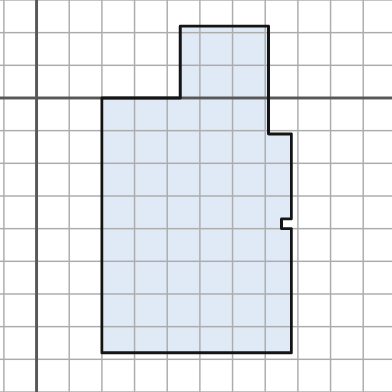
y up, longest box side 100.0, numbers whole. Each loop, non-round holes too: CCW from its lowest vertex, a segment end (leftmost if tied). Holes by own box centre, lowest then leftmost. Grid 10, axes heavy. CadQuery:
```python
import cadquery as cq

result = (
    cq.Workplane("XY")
    .moveTo(20.0, -78.0)
    .lineTo(78.0, -78.0)
    .lineTo(78.0, -40.0)
    .lineTo(75.0, -40.0)
    .lineTo(75.0, -37.0)
    .lineTo(78.0, -37.0)
    .lineTo(78.0, -11.0)
    .lineTo(71.0, -11.0)
    .lineTo(71.0, 22.0)
    .lineTo(44.0, 22.0)
    .lineTo(44.0, 0.0)
    .lineTo(20.0, 0.0)
    .close()
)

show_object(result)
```